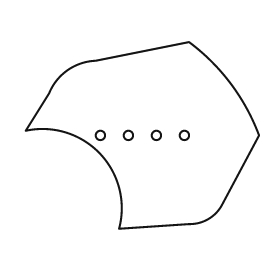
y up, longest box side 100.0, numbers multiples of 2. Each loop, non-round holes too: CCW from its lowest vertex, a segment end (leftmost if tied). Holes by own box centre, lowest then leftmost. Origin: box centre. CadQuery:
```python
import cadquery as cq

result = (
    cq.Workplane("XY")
    .moveTo(-10.0, -40.0)
    .lineTo(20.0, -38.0)
    .threePointArc((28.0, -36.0), (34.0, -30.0))
    .lineTo(50.0, 0.0)
    .threePointArc((38.0, 22.0), (20.0, 40.0))
    .lineTo(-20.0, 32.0)
    .threePointArc((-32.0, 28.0), (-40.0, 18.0))
    .lineTo(-50.0, 2.0)
    .threePointArc((-18.0, -8.0), (-10.0, -40.0))
    .close()
    .moveTo(-18.0, 0.0)
    .circle(2.0)
    .moveTo(-6.0, 0.0)
    .circle(2.0)
    .moveTo(6.0, 0.0)
    .circle(2.0)
    .moveTo(18.0, 0.0)
    .circle(2.0)
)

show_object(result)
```